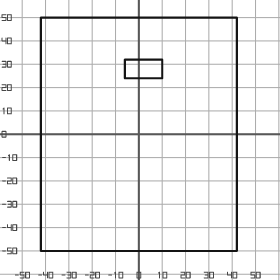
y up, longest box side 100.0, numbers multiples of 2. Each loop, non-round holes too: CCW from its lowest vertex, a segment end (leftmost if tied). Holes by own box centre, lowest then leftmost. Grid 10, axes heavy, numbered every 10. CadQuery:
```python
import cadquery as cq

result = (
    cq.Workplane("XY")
    .moveTo(-42.0, -50.0)
    .lineTo(42.0, -50.0)
    .lineTo(42.0, 50.0)
    .lineTo(-42.0, 50.0)
    .close()
    .moveTo(-6.0, 24.0)
    .lineTo(10.0, 24.0)
    .lineTo(10.0, 32.0)
    .lineTo(-6.0, 32.0)
    .close()
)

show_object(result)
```